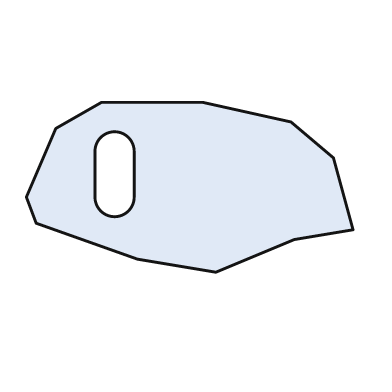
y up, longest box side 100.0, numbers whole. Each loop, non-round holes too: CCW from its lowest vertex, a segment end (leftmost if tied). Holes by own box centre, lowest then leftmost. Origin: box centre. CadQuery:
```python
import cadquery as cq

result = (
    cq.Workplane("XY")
    .moveTo(8.0, -26.0)
    .lineTo(32.0, -16.0)
    .lineTo(50.0, -13.0)
    .lineTo(44.0, 9.0)
    .lineTo(31.0, 20.0)
    .lineTo(4.0, 26.0)
    .lineTo(-27.0, 26.0)
    .lineTo(-41.0, 18.0)
    .lineTo(-50.0, -3.0)
    .lineTo(-47.0, -11.0)
    .lineTo(-16.0, -22.0)
    .close()
    .moveTo(-29.0, -3.0)
    .threePointArc((-23.0, -9.0), (-17.0, -3.0))
    .lineTo(-17.0, 11.0)
    .threePointArc((-23.0, 17.0), (-29.0, 11.0))
    .close()
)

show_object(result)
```